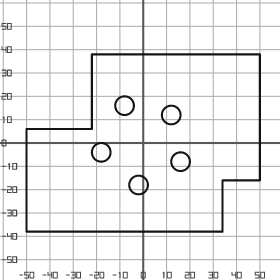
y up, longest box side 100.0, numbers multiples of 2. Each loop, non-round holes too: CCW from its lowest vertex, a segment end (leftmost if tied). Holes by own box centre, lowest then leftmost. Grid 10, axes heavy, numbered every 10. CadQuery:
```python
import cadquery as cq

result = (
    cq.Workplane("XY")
    .moveTo(-50.0, -38.0)
    .lineTo(34.0, -38.0)
    .lineTo(34.0, -16.0)
    .lineTo(50.0, -16.0)
    .lineTo(50.0, 38.0)
    .lineTo(-22.0, 38.0)
    .lineTo(-22.0, 6.0)
    .lineTo(-50.0, 6.0)
    .close()
    .moveTo(-2.0, -18.0)
    .circle(4.0)
    .moveTo(16.0, -8.0)
    .circle(4.0)
    .moveTo(-18.0, -4.0)
    .circle(4.0)
    .moveTo(12.0, 12.0)
    .circle(4.0)
    .moveTo(-8.0, 16.0)
    .circle(4.0)
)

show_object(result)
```